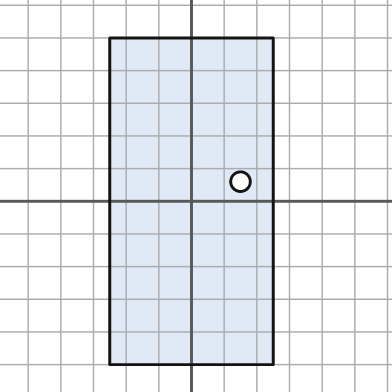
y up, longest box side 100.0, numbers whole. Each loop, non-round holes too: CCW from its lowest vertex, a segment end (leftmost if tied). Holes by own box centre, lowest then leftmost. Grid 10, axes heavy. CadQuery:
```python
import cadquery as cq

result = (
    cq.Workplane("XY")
    .moveTo(-25.0, -50.0)
    .lineTo(25.0, -50.0)
    .lineTo(25.0, 50.0)
    .lineTo(-25.0, 50.0)
    .close()
    .moveTo(15.0, 6.0)
    .circle(3.0)
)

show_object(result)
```